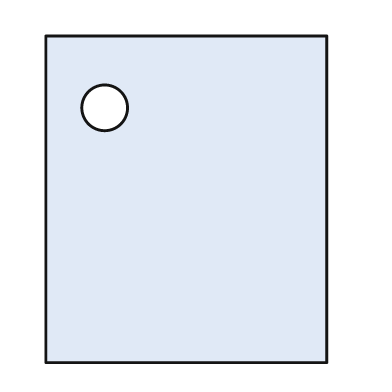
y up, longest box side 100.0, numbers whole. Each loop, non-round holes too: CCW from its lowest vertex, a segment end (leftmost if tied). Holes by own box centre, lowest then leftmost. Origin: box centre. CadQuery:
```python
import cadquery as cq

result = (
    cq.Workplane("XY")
    .moveTo(-43.0, -50.0)
    .lineTo(43.0, -50.0)
    .lineTo(43.0, 50.0)
    .lineTo(-43.0, 50.0)
    .close()
    .moveTo(-25.0, 28.0)
    .circle(7.0)
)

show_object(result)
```